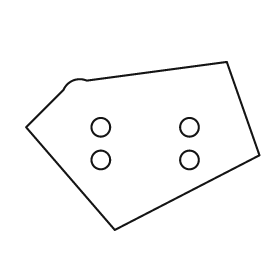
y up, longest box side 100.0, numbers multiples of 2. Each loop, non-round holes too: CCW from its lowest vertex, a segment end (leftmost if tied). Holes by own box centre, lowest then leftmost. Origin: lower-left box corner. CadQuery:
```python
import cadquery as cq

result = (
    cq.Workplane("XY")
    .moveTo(38.0, 0.0)
    .lineTo(100.0, 32.0)
    .lineTo(86.0, 72.0)
    .lineTo(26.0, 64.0)
    .threePointArc((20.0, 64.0), (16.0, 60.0))
    .lineTo(0.0, 44.0)
    .close()
    .moveTo(32.0, 30.0)
    .circle(4.0)
    .moveTo(70.0, 30.0)
    .circle(4.0)
    .moveTo(32.0, 44.0)
    .circle(4.0)
    .moveTo(70.0, 44.0)
    .circle(4.0)
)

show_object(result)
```